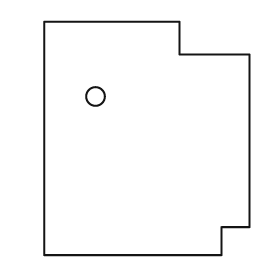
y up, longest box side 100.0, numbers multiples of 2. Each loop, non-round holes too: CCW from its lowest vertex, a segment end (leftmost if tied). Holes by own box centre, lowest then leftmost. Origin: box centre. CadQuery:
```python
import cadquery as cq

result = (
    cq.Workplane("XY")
    .moveTo(-44.0, -50.0)
    .lineTo(32.0, -50.0)
    .lineTo(32.0, -38.0)
    .lineTo(44.0, -38.0)
    .lineTo(44.0, 36.0)
    .lineTo(14.0, 36.0)
    .lineTo(14.0, 50.0)
    .lineTo(-44.0, 50.0)
    .close()
    .moveTo(-22.0, 18.0)
    .circle(4.0)
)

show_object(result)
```